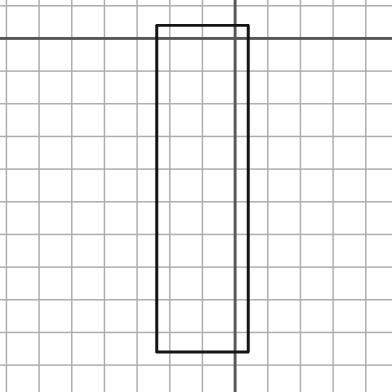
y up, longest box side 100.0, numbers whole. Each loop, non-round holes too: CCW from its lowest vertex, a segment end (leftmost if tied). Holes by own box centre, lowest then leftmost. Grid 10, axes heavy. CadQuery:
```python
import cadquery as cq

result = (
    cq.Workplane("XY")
    .moveTo(-24.0, -96.0)
    .lineTo(4.0, -96.0)
    .lineTo(4.0, 4.0)
    .lineTo(-24.0, 4.0)
    .close()
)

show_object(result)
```